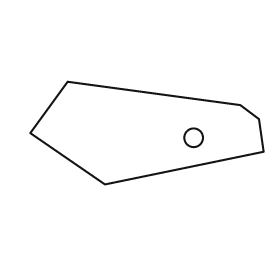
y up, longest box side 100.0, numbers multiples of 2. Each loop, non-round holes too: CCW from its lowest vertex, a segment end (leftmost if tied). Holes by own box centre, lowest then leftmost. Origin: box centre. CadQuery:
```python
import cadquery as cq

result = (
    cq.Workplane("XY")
    .moveTo(-18.0, -22.0)
    .lineTo(50.0, -8.0)
    .lineTo(48.0, 6.0)
    .lineTo(40.0, 12.0)
    .lineTo(-34.0, 22.0)
    .lineTo(-50.0, 0.0)
    .close()
    .moveTo(20.0, -2.0)
    .circle(4.0)
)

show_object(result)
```